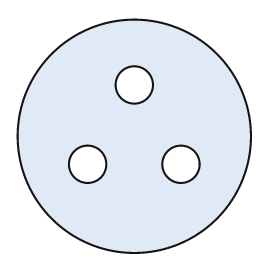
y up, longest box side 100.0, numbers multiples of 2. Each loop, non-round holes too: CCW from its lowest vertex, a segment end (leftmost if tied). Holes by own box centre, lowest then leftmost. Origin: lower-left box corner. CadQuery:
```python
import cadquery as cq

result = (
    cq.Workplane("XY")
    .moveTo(50.0, 50.0)
    .circle(50.0)
    .moveTo(30.0, 38.0)
    .circle(8.0)
    .moveTo(70.0, 38.0)
    .circle(8.0)
    .moveTo(50.0, 72.0)
    .circle(8.0)
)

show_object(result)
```